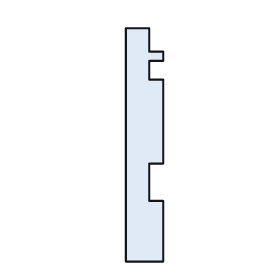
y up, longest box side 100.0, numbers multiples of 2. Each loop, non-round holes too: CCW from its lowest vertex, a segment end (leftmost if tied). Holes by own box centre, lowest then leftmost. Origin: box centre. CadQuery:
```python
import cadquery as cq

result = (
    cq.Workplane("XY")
    .moveTo(-8.0, -50.0)
    .lineTo(8.0, -50.0)
    .lineTo(8.0, -24.0)
    .lineTo(2.0, -24.0)
    .lineTo(2.0, -8.0)
    .lineTo(8.0, -8.0)
    .lineTo(8.0, 28.0)
    .lineTo(2.0, 28.0)
    .lineTo(2.0, 36.0)
    .lineTo(8.0, 36.0)
    .lineTo(8.0, 40.0)
    .lineTo(2.0, 40.0)
    .lineTo(2.0, 50.0)
    .lineTo(-8.0, 50.0)
    .close()
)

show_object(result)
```